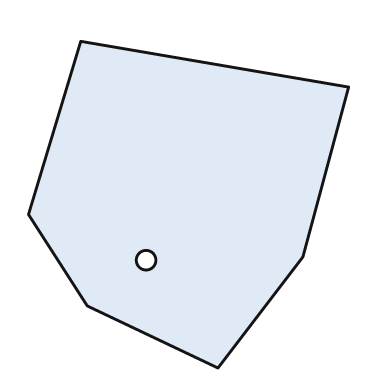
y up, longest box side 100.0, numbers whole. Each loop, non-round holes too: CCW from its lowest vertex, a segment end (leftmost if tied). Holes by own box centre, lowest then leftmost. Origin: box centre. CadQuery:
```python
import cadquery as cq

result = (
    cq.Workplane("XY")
    .moveTo(9.0, -50.0)
    .lineTo(35.0, -16.0)
    .lineTo(49.0, 36.0)
    .lineTo(-33.0, 50.0)
    .lineTo(-49.0, -3.0)
    .lineTo(-31.0, -31.0)
    .close()
    .moveTo(-13.0, -17.0)
    .circle(3.0)
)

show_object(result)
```